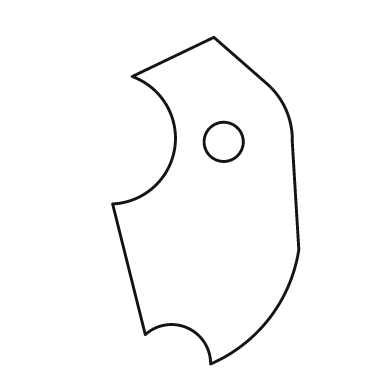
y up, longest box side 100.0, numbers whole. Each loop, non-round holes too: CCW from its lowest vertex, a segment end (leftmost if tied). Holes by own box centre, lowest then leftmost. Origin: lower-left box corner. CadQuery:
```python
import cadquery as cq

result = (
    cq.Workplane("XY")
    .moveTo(30.0, 0.0)
    .threePointArc((48.0, 14.0), (57.0, 35.0))
    .lineTo(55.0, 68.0)
    .threePointArc((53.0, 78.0), (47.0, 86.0))
    .lineTo(31.0, 100.0)
    .lineTo(6.0, 88.0)
    .threePointArc((19.0, 66.0), (0.0, 49.0))
    .lineTo(10.0, 9.0)
    .threePointArc((23.0, 11.0), (30.0, 0.0))
    .close()
    .moveTo(34.0, 68.0)
    .circle(6.0)
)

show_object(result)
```